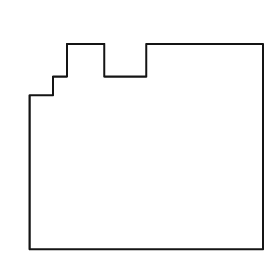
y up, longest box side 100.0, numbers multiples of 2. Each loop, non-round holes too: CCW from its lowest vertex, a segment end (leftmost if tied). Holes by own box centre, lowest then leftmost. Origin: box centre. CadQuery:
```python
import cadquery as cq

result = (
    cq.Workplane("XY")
    .moveTo(-50.0, -44.0)
    .lineTo(50.0, -44.0)
    .lineTo(50.0, 44.0)
    .lineTo(0.0, 44.0)
    .lineTo(0.0, 30.0)
    .lineTo(-18.0, 30.0)
    .lineTo(-18.0, 44.0)
    .lineTo(-34.0, 44.0)
    .lineTo(-34.0, 30.0)
    .lineTo(-40.0, 30.0)
    .lineTo(-40.0, 22.0)
    .lineTo(-50.0, 22.0)
    .close()
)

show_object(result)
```